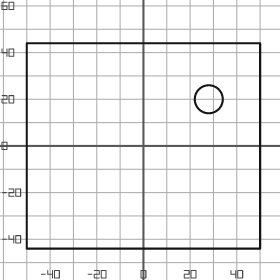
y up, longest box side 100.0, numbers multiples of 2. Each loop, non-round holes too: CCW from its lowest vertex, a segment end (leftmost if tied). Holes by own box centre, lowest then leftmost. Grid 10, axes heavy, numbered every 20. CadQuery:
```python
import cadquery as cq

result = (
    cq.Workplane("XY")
    .moveTo(-50.0, -44.0)
    .lineTo(50.0, -44.0)
    .lineTo(50.0, 44.0)
    .lineTo(-50.0, 44.0)
    .close()
    .moveTo(28.0, 20.0)
    .circle(6.0)
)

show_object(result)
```